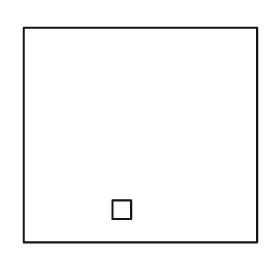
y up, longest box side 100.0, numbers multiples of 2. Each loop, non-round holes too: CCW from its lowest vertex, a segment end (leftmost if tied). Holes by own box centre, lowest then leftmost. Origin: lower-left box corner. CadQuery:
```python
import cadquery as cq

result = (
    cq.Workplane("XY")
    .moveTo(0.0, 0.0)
    .lineTo(100.0, 0.0)
    .lineTo(100.0, 92.0)
    .lineTo(0.0, 92.0)
    .close()
    .moveTo(38.0, 10.0)
    .lineTo(46.0, 10.0)
    .lineTo(46.0, 18.0)
    .lineTo(38.0, 18.0)
    .close()
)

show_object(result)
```